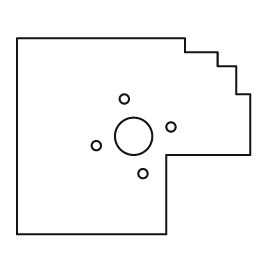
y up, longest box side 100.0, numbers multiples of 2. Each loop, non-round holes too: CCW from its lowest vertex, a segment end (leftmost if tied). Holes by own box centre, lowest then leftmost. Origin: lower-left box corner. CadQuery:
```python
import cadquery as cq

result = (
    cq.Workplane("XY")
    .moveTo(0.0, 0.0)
    .lineTo(64.0, 0.0)
    .lineTo(64.0, 34.0)
    .lineTo(100.0, 34.0)
    .lineTo(100.0, 60.0)
    .lineTo(94.0, 60.0)
    .lineTo(94.0, 72.0)
    .lineTo(86.0, 72.0)
    .lineTo(86.0, 78.0)
    .lineTo(72.0, 78.0)
    .lineTo(72.0, 84.0)
    .lineTo(0.0, 84.0)
    .close()
    .moveTo(54.0, 26.0)
    .circle(2.0)
    .moveTo(34.0, 38.0)
    .circle(2.0)
    .moveTo(50.0, 42.0)
    .circle(8.0)
    .moveTo(66.0, 46.0)
    .circle(2.0)
    .moveTo(46.0, 58.0)
    .circle(2.0)
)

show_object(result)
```